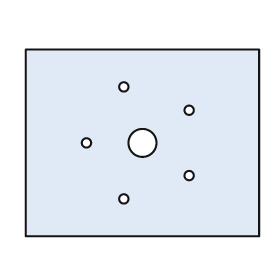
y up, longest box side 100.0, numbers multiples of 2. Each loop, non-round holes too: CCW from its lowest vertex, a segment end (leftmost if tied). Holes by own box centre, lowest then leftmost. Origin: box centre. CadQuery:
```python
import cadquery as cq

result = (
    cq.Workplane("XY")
    .moveTo(-50.0, -40.0)
    .lineTo(50.0, -40.0)
    .lineTo(50.0, 40.0)
    .lineTo(-50.0, 40.0)
    .close()
    .moveTo(-8.0, -24.0)
    .circle(2.0)
    .moveTo(20.0, -14.0)
    .circle(2.0)
    .moveTo(-24.0, 0.0)
    .circle(2.0)
    .moveTo(0.0, 0.0)
    .circle(6.0)
    .moveTo(20.0, 14.0)
    .circle(2.0)
    .moveTo(-8.0, 24.0)
    .circle(2.0)
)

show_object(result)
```